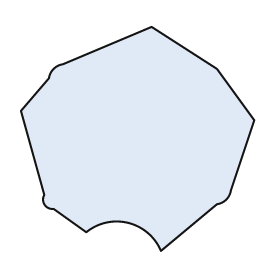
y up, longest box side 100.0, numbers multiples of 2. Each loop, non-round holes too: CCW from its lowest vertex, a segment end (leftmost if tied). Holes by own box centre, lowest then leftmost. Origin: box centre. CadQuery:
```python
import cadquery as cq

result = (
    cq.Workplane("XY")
    .moveTo(10.0, -48.0)
    .lineTo(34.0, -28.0)
    .threePointArc((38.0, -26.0), (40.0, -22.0))
    .lineTo(50.0, 8.0)
    .lineTo(34.0, 30.0)
    .lineTo(6.0, 48.0)
    .lineTo(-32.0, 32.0)
    .threePointArc((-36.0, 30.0), (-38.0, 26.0))
    .lineTo(-50.0, 12.0)
    .lineTo(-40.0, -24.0)
    .threePointArc((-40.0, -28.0), (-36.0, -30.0))
    .lineTo(-22.0, -40.0)
    .threePointArc((-4.0, -36.0), (10.0, -48.0))
    .close()
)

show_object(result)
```